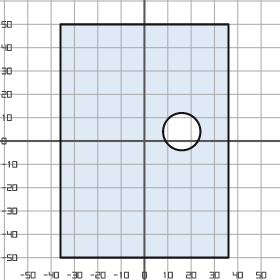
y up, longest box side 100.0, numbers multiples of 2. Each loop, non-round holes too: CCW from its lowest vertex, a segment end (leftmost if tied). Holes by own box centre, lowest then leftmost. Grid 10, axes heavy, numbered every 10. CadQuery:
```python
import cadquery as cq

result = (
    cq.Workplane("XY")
    .moveTo(-36.0, -50.0)
    .lineTo(36.0, -50.0)
    .lineTo(36.0, 50.0)
    .lineTo(-36.0, 50.0)
    .close()
    .moveTo(16.0, 4.0)
    .circle(8.0)
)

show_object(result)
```